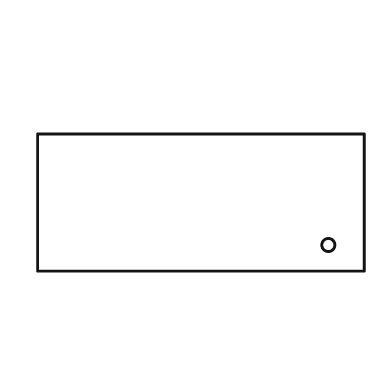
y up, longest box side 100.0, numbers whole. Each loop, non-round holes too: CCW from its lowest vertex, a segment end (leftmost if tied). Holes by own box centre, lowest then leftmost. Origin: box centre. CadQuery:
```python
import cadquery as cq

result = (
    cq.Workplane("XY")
    .moveTo(-50.0, -21.0)
    .lineTo(50.0, -21.0)
    .lineTo(50.0, 21.0)
    .lineTo(-50.0, 21.0)
    .close()
    .moveTo(39.0, -13.0)
    .circle(2.0)
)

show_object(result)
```